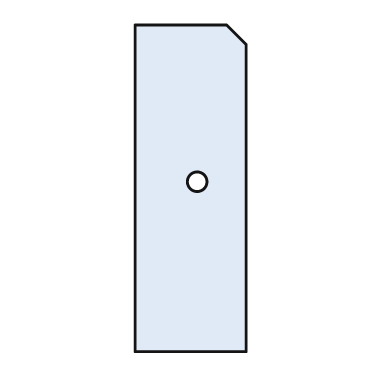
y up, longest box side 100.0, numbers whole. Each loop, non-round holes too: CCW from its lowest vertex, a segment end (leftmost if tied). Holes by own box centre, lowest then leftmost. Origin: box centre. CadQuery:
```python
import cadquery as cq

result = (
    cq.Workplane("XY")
    .moveTo(-17.0, -50.0)
    .lineTo(17.0, -50.0)
    .lineTo(17.0, 44.0)
    .lineTo(11.0, 50.0)
    .lineTo(-17.0, 50.0)
    .close()
    .moveTo(2.0, 2.0)
    .circle(3.0)
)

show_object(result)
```